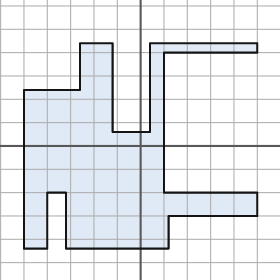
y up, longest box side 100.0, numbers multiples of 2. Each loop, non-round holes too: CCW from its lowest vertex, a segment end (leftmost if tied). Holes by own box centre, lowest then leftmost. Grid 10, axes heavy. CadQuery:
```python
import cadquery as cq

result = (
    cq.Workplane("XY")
    .moveTo(-50.0, -44.0)
    .lineTo(-40.0, -44.0)
    .lineTo(-40.0, -20.0)
    .lineTo(-32.0, -20.0)
    .lineTo(-32.0, -44.0)
    .lineTo(12.0, -44.0)
    .lineTo(12.0, -30.0)
    .lineTo(50.0, -30.0)
    .lineTo(50.0, -20.0)
    .lineTo(10.0, -20.0)
    .lineTo(10.0, 40.0)
    .lineTo(50.0, 40.0)
    .lineTo(50.0, 44.0)
    .lineTo(4.0, 44.0)
    .lineTo(4.0, 6.0)
    .lineTo(-12.0, 6.0)
    .lineTo(-12.0, 44.0)
    .lineTo(-26.0, 44.0)
    .lineTo(-26.0, 24.0)
    .lineTo(-50.0, 24.0)
    .close()
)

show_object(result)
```